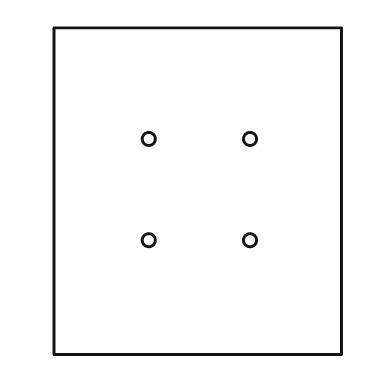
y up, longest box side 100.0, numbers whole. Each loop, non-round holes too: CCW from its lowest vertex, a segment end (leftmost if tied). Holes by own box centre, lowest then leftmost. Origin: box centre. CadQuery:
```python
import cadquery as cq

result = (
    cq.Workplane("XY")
    .moveTo(-44.0, -50.0)
    .lineTo(44.0, -50.0)
    .lineTo(44.0, 50.0)
    .lineTo(-44.0, 50.0)
    .close()
    .moveTo(-15.0, -15.0)
    .circle(2.0)
    .moveTo(16.0, -15.0)
    .circle(2.0)
    .moveTo(-15.0, 16.0)
    .circle(2.0)
    .moveTo(16.0, 16.0)
    .circle(2.0)
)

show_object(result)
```